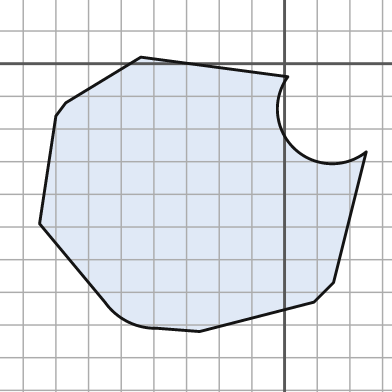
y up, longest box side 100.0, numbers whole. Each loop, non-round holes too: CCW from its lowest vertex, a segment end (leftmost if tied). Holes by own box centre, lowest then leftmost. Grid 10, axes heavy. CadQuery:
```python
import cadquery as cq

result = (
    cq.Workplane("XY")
    .moveTo(-26.0, -82.0)
    .lineTo(9.0, -73.0)
    .lineTo(15.0, -67.0)
    .lineTo(25.0, -27.0)
    .threePointArc((3.0, -26.0), (1.0, -4.0))
    .lineTo(-44.0, 2.0)
    .lineTo(-67.0, -12.0)
    .lineTo(-70.0, -16.0)
    .lineTo(-75.0, -49.0)
    .lineTo(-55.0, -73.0)
    .threePointArc((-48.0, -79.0), (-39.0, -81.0))
    .close()
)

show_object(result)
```